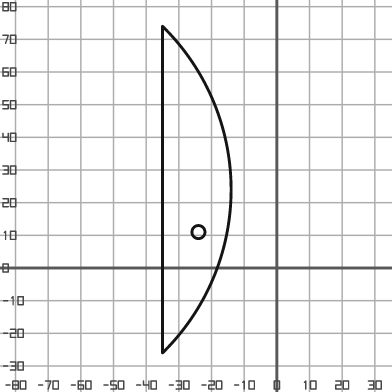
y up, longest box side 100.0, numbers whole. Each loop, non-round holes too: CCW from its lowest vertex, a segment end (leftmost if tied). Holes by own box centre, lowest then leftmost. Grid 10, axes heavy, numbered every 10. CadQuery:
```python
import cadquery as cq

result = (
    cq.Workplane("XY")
    .moveTo(-35.0, -26.0)
    .threePointArc((-14.0, 24.0), (-35.0, 74.0))
    .close()
    .moveTo(-24.0, 11.0)
    .circle(2.0)
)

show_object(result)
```